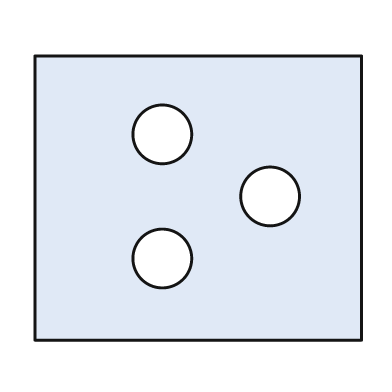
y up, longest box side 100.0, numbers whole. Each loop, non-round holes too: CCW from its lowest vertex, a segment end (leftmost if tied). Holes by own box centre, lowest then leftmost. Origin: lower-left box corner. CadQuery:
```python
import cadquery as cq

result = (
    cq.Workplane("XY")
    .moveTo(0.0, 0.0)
    .lineTo(100.0, 0.0)
    .lineTo(100.0, 87.0)
    .lineTo(0.0, 87.0)
    .close()
    .moveTo(39.0, 25.0)
    .circle(9.0)
    .moveTo(72.0, 44.0)
    .circle(9.0)
    .moveTo(39.0, 63.0)
    .circle(9.0)
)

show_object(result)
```